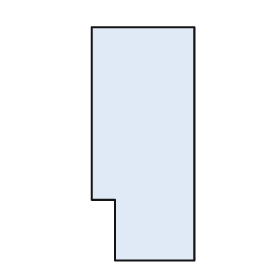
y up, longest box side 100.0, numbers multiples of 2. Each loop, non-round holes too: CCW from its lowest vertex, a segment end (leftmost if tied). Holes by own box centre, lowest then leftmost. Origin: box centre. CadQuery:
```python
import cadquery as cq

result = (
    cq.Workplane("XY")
    .moveTo(-12.0, -50.0)
    .lineTo(22.0, -50.0)
    .lineTo(22.0, 50.0)
    .lineTo(-22.0, 50.0)
    .lineTo(-22.0, -24.0)
    .lineTo(-12.0, -24.0)
    .close()
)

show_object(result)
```